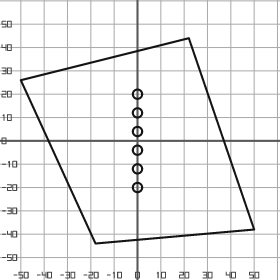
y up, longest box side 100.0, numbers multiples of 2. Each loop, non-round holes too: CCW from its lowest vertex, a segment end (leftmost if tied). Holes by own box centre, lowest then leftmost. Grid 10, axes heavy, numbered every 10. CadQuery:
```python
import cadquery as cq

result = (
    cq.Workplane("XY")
    .moveTo(-18.0, -44.0)
    .lineTo(50.0, -38.0)
    .lineTo(22.0, 44.0)
    .lineTo(-50.0, 26.0)
    .close()
    .moveTo(0.0, -20.0)
    .circle(2.0)
    .moveTo(0.0, -12.0)
    .circle(2.0)
    .moveTo(0.0, -4.0)
    .circle(2.0)
    .moveTo(0.0, 4.0)
    .circle(2.0)
    .moveTo(0.0, 12.0)
    .circle(2.0)
    .moveTo(0.0, 20.0)
    .circle(2.0)
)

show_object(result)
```